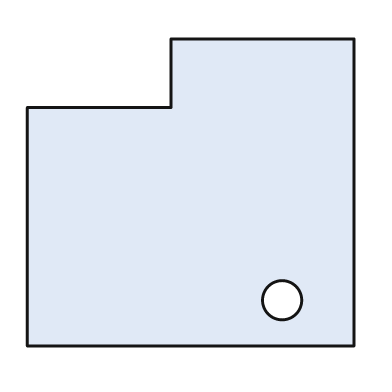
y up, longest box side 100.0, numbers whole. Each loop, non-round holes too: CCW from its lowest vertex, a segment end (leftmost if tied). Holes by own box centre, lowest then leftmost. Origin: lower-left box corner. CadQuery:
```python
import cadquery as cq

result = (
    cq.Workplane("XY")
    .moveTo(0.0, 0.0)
    .lineTo(100.0, 0.0)
    .lineTo(100.0, 94.0)
    .lineTo(44.0, 94.0)
    .lineTo(44.0, 73.0)
    .lineTo(0.0, 73.0)
    .close()
    .moveTo(78.0, 14.0)
    .circle(6.0)
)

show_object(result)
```